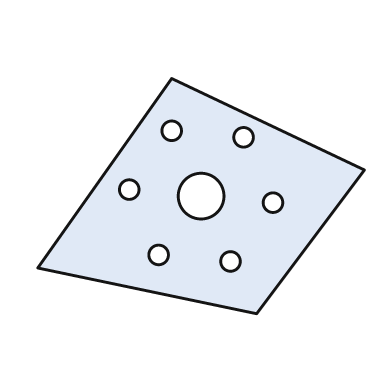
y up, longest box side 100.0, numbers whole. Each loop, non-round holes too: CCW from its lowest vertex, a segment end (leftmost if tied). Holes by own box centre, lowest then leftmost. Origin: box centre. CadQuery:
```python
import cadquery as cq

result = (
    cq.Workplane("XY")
    .moveTo(17.0, -36.0)
    .lineTo(50.0, 8.0)
    .lineTo(-9.0, 36.0)
    .lineTo(-50.0, -22.0)
    .close()
    .moveTo(9.0, -20.0)
    .circle(3.0)
    .moveTo(-13.0, -18.0)
    .circle(3.0)
    .moveTo(22.0, -2.0)
    .circle(3.0)
    .moveTo(0.0, 0.0)
    .circle(7.0)
    .moveTo(-22.0, 2.0)
    .circle(3.0)
    .moveTo(13.0, 18.0)
    .circle(3.0)
    .moveTo(-9.0, 20.0)
    .circle(3.0)
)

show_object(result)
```